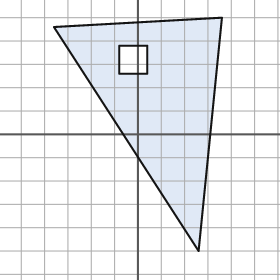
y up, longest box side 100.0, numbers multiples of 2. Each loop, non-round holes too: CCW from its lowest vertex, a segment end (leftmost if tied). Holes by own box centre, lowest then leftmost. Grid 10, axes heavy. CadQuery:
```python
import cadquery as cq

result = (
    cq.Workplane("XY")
    .moveTo(26.0, -50.0)
    .lineTo(36.0, 50.0)
    .lineTo(-36.0, 46.0)
    .close()
    .moveTo(-8.0, 26.0)
    .lineTo(4.0, 26.0)
    .lineTo(4.0, 38.0)
    .lineTo(-8.0, 38.0)
    .close()
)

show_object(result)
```